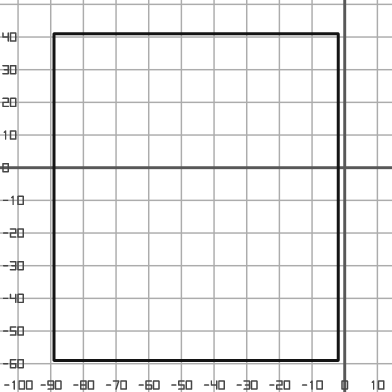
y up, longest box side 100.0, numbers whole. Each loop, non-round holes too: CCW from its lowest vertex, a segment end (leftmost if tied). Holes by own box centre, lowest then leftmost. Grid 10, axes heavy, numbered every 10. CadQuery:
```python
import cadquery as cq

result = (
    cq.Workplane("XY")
    .moveTo(-89.0, -59.0)
    .lineTo(-2.0, -59.0)
    .lineTo(-2.0, 41.0)
    .lineTo(-89.0, 41.0)
    .close()
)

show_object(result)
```